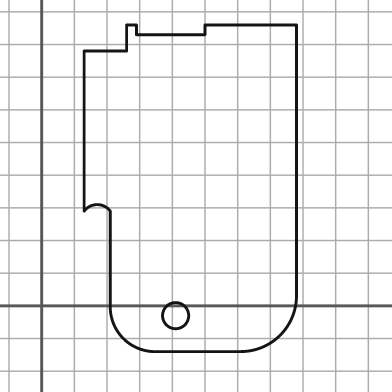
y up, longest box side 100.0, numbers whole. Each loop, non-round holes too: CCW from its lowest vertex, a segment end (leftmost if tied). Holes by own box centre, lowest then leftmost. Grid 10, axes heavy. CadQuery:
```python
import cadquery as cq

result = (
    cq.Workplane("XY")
    .moveTo(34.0, -14.0)
    .lineTo(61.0, -14.0)
    .threePointArc((73.0, -9.0), (78.0, 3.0))
    .lineTo(78.0, 86.0)
    .lineTo(50.0, 86.0)
    .lineTo(50.0, 83.0)
    .lineTo(29.0, 83.0)
    .lineTo(29.0, 86.0)
    .lineTo(26.0, 86.0)
    .lineTo(26.0, 78.0)
    .lineTo(13.0, 78.0)
    .lineTo(13.0, 29.0)
    .threePointArc((17.0, 31.0), (21.0, 29.0))
    .lineTo(21.0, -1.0)
    .threePointArc((25.0, -10.0), (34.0, -14.0))
    .close()
    .moveTo(41.0, -3.0)
    .circle(4.0)
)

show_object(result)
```